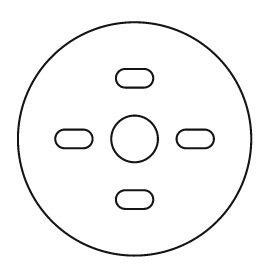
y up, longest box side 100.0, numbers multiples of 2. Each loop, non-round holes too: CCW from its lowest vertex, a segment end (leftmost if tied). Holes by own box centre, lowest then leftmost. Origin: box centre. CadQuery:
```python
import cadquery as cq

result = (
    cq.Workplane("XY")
    .moveTo(0.0, 0.0)
    .circle(50.0)
    .moveTo(-4.0, -30.0)
    .lineTo(4.0, -30.0)
    .threePointArc((8.0, -26.0), (4.0, -22.0))
    .lineTo(-4.0, -22.0)
    .threePointArc((-8.0, -26.0), (-4.0, -30.0))
    .close()
    .moveTo(-30.0, -4.0)
    .lineTo(-22.0, -4.0)
    .threePointArc((-18.0, 0.0), (-22.0, 4.0))
    .lineTo(-30.0, 4.0)
    .threePointArc((-34.0, 0.0), (-30.0, -4.0))
    .close()
    .moveTo(0.0, 0.0)
    .circle(10.0)
    .moveTo(22.0, -4.0)
    .lineTo(30.0, -4.0)
    .threePointArc((34.0, 0.0), (30.0, 4.0))
    .lineTo(22.0, 4.0)
    .threePointArc((18.0, 0.0), (22.0, -4.0))
    .close()
    .moveTo(-4.0, 22.0)
    .lineTo(4.0, 22.0)
    .threePointArc((8.0, 26.0), (4.0, 30.0))
    .lineTo(-4.0, 30.0)
    .threePointArc((-8.0, 26.0), (-4.0, 22.0))
    .close()
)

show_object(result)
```